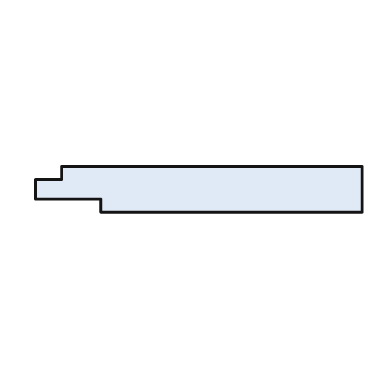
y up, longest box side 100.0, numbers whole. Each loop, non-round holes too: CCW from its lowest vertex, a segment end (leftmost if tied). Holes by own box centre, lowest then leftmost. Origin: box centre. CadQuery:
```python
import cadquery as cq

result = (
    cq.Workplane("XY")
    .moveTo(-30.0, -7.0)
    .lineTo(50.0, -7.0)
    .lineTo(50.0, 7.0)
    .lineTo(-42.0, 7.0)
    .lineTo(-42.0, 3.0)
    .lineTo(-50.0, 3.0)
    .lineTo(-50.0, -3.0)
    .lineTo(-30.0, -3.0)
    .close()
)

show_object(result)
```